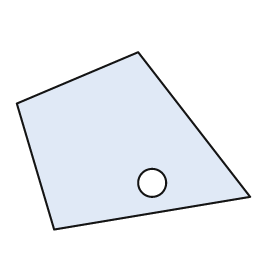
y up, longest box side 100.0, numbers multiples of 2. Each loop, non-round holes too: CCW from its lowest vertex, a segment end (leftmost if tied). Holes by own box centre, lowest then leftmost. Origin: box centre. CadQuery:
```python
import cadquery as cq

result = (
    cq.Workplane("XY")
    .moveTo(-34.0, -38.0)
    .lineTo(50.0, -24.0)
    .lineTo(2.0, 38.0)
    .lineTo(-50.0, 16.0)
    .close()
    .moveTo(8.0, -18.0)
    .circle(6.0)
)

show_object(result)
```